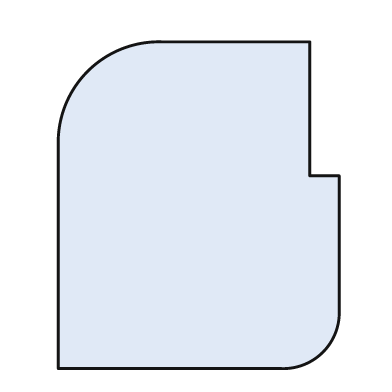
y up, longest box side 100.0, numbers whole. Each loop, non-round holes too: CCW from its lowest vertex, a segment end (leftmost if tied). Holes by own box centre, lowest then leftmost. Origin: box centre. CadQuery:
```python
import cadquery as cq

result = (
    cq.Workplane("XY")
    .moveTo(-43.0, -50.0)
    .lineTo(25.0, -50.0)
    .threePointArc((38.0, -45.0), (43.0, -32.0))
    .lineTo(43.0, 9.0)
    .lineTo(34.0, 9.0)
    .lineTo(34.0, 50.0)
    .lineTo(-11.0, 50.0)
    .threePointArc((-34.0, 41.0), (-43.0, 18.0))
    .close()
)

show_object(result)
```